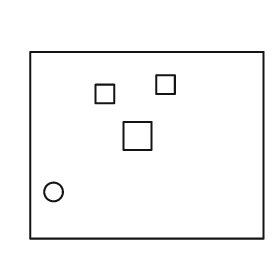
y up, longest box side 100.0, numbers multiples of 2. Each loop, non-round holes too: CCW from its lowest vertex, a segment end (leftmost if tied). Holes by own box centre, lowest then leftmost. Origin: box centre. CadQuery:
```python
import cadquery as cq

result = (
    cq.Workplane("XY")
    .moveTo(-50.0, -40.0)
    .lineTo(50.0, -40.0)
    .lineTo(50.0, 40.0)
    .lineTo(-50.0, 40.0)
    .close()
    .moveTo(-40.0, -20.0)
    .circle(4.0)
    .moveTo(-10.0, -2.0)
    .lineTo(2.0, -2.0)
    .lineTo(2.0, 10.0)
    .lineTo(-10.0, 10.0)
    .close()
    .moveTo(-22.0, 18.0)
    .lineTo(-14.0, 18.0)
    .lineTo(-14.0, 26.0)
    .lineTo(-22.0, 26.0)
    .close()
    .moveTo(4.0, 22.0)
    .lineTo(12.0, 22.0)
    .lineTo(12.0, 30.0)
    .lineTo(4.0, 30.0)
    .close()
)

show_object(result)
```